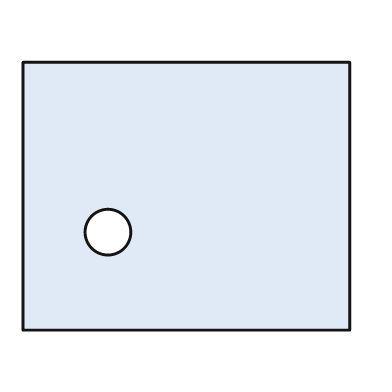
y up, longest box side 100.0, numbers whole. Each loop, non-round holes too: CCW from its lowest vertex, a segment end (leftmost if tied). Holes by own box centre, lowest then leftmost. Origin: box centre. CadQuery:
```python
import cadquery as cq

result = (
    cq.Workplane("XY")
    .moveTo(-50.0, -41.0)
    .lineTo(50.0, -41.0)
    .lineTo(50.0, 41.0)
    .lineTo(-50.0, 41.0)
    .close()
    .moveTo(-24.0, -11.0)
    .circle(7.0)
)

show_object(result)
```